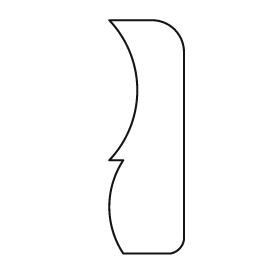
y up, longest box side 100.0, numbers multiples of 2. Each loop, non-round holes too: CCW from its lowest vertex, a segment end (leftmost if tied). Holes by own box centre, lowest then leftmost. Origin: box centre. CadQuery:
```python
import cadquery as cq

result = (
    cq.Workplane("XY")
    .moveTo(-10.0, -50.0)
    .lineTo(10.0, -50.0)
    .threePointArc((14.0, -48.0), (16.0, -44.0))
    .lineTo(16.0, 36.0)
    .threePointArc((12.0, 46.0), (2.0, 50.0))
    .lineTo(-16.0, 50.0)
    .threePointArc((-4.0, 20.0), (-16.0, -10.0))
    .lineTo(-10.0, -10.0)
    .threePointArc((-16.0, -30.0), (-10.0, -50.0))
    .close()
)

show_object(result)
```